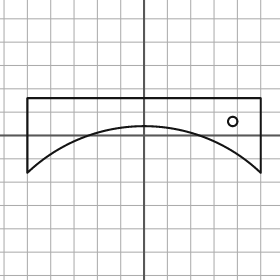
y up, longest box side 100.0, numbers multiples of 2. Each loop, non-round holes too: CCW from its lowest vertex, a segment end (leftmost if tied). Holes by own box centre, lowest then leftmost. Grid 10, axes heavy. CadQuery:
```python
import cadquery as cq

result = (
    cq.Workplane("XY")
    .moveTo(-50.0, -16.0)
    .threePointArc((0.0, 4.0), (50.0, -16.0))
    .lineTo(50.0, 16.0)
    .lineTo(-50.0, 16.0)
    .close()
    .moveTo(38.0, 6.0)
    .circle(2.0)
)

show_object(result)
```